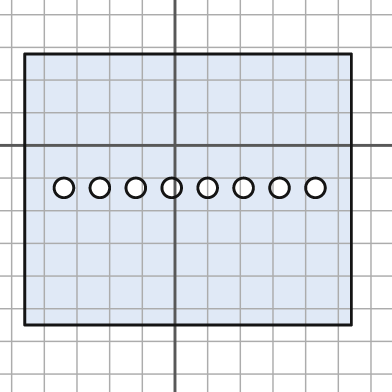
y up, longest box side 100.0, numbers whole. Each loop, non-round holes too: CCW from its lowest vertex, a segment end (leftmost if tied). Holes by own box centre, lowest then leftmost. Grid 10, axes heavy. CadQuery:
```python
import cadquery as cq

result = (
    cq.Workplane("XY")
    .moveTo(-46.0, -55.0)
    .lineTo(54.0, -55.0)
    .lineTo(54.0, 28.0)
    .lineTo(-46.0, 28.0)
    .close()
    .moveTo(-34.0, -13.0)
    .circle(3.0)
    .moveTo(-23.0, -13.0)
    .circle(3.0)
    .moveTo(-12.0, -13.0)
    .circle(3.0)
    .moveTo(-1.0, -13.0)
    .circle(3.0)
    .moveTo(10.0, -13.0)
    .circle(3.0)
    .moveTo(21.0, -13.0)
    .circle(3.0)
    .moveTo(32.0, -13.0)
    .circle(3.0)
    .moveTo(43.0, -13.0)
    .circle(3.0)
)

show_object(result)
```